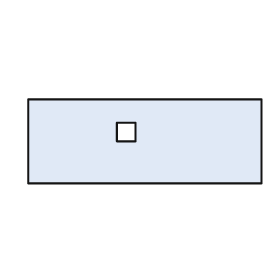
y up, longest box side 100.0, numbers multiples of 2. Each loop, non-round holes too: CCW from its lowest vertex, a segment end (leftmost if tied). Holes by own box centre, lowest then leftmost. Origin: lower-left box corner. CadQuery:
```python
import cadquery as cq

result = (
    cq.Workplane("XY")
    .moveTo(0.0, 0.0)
    .lineTo(100.0, 0.0)
    .lineTo(100.0, 36.0)
    .lineTo(0.0, 36.0)
    .close()
    .moveTo(38.0, 18.0)
    .lineTo(46.0, 18.0)
    .lineTo(46.0, 26.0)
    .lineTo(38.0, 26.0)
    .close()
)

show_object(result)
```